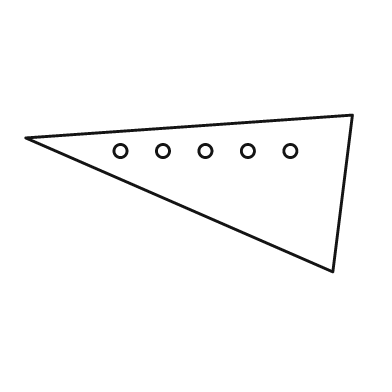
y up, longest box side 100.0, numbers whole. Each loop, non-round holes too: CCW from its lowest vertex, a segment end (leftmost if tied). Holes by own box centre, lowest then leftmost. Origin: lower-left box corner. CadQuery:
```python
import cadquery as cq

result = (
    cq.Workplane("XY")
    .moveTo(94.0, 0.0)
    .lineTo(100.0, 48.0)
    .lineTo(0.0, 41.0)
    .close()
    .moveTo(29.0, 37.0)
    .circle(2.0)
    .moveTo(42.0, 37.0)
    .circle(2.0)
    .moveTo(55.0, 37.0)
    .circle(2.0)
    .moveTo(68.0, 37.0)
    .circle(2.0)
    .moveTo(81.0, 37.0)
    .circle(2.0)
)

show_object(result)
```